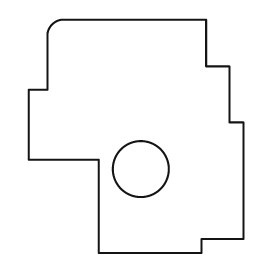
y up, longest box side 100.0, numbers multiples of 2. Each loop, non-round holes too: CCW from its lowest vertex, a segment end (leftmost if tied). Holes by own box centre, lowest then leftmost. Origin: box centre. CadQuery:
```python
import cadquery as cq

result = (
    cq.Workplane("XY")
    .moveTo(-16.0, -50.0)
    .lineTo(28.0, -50.0)
    .lineTo(28.0, -44.0)
    .lineTo(46.0, -44.0)
    .lineTo(46.0, 6.0)
    .lineTo(40.0, 6.0)
    .lineTo(40.0, 30.0)
    .lineTo(30.0, 30.0)
    .lineTo(30.0, 50.0)
    .lineTo(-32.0, 50.0)
    .threePointArc((-36.0, 48.0), (-38.0, 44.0))
    .lineTo(-38.0, 20.0)
    .lineTo(-46.0, 20.0)
    .lineTo(-46.0, -10.0)
    .lineTo(-16.0, -10.0)
    .close()
    .moveTo(2.0, -14.0)
    .circle(12.0)
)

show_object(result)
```